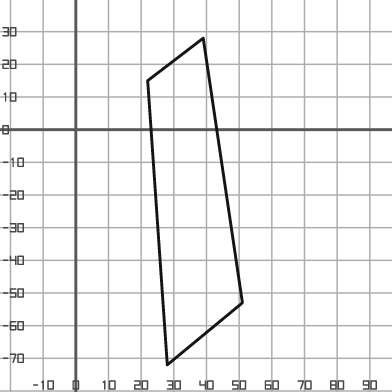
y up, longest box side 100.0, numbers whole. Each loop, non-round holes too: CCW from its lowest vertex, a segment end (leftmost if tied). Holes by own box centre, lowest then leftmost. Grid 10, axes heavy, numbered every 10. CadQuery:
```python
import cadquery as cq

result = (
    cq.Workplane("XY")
    .moveTo(28.0, -72.0)
    .lineTo(51.0, -53.0)
    .lineTo(39.0, 28.0)
    .lineTo(22.0, 15.0)
    .close()
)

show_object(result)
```